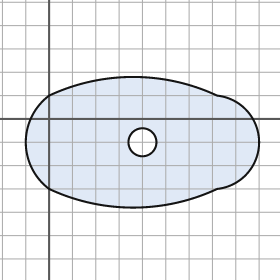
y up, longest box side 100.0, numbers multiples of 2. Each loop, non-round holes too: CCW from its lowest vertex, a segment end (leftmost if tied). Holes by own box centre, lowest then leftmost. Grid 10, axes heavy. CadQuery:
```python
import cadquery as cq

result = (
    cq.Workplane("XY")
    .moveTo(0.0, -30.0)
    .threePointArc((36.0, -38.0), (72.0, -30.0))
    .threePointArc((90.0, -10.0), (72.0, 10.0))
    .threePointArc((36.0, 18.0), (0.0, 10.0))
    .threePointArc((-10.0, -10.0), (0.0, -30.0))
    .close()
    .moveTo(40.0, -10.0)
    .circle(6.0)
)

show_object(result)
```